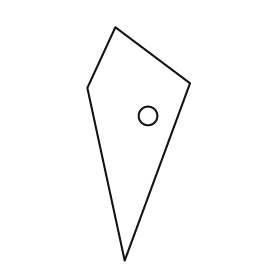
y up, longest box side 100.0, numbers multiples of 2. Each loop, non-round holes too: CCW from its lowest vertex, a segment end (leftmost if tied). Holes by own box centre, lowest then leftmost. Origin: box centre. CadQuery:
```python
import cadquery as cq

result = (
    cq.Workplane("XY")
    .moveTo(-6.0, -50.0)
    .lineTo(22.0, 26.0)
    .lineTo(-10.0, 50.0)
    .lineTo(-22.0, 24.0)
    .close()
    .moveTo(4.0, 12.0)
    .circle(4.0)
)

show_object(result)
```